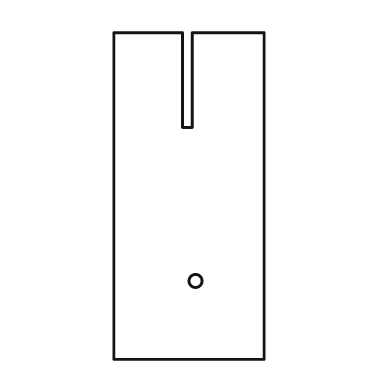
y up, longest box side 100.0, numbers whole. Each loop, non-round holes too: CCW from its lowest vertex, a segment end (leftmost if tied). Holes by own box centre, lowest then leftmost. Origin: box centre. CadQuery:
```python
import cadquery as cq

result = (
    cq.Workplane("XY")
    .moveTo(-23.0, -50.0)
    .lineTo(23.0, -50.0)
    .lineTo(23.0, 50.0)
    .lineTo(1.0, 50.0)
    .lineTo(1.0, 21.0)
    .lineTo(-2.0, 21.0)
    .lineTo(-2.0, 50.0)
    .lineTo(-23.0, 50.0)
    .close()
    .moveTo(2.0, -26.0)
    .circle(2.0)
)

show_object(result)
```